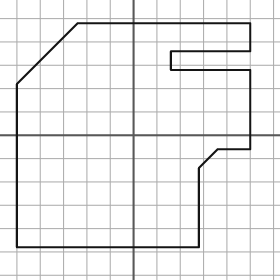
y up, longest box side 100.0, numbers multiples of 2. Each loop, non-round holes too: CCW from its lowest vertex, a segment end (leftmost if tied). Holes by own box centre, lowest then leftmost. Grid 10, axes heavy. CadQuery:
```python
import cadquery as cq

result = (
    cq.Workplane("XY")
    .moveTo(-50.0, -48.0)
    .lineTo(28.0, -48.0)
    .lineTo(28.0, -14.0)
    .lineTo(36.0, -6.0)
    .lineTo(50.0, -6.0)
    .lineTo(50.0, 28.0)
    .lineTo(16.0, 28.0)
    .lineTo(16.0, 36.0)
    .lineTo(50.0, 36.0)
    .lineTo(50.0, 48.0)
    .lineTo(-24.0, 48.0)
    .lineTo(-50.0, 22.0)
    .close()
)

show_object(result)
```